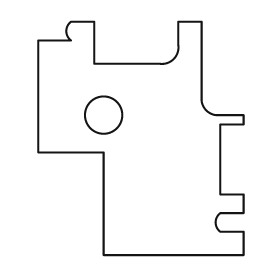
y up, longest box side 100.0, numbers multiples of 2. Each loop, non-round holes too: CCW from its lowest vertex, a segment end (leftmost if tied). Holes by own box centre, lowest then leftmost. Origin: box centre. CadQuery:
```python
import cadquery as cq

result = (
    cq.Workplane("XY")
    .moveTo(-16.0, -50.0)
    .lineTo(44.0, -50.0)
    .lineTo(44.0, -40.0)
    .lineTo(34.0, -40.0)
    .threePointArc((32.0, -36.0), (34.0, -32.0))
    .lineTo(44.0, -32.0)
    .lineTo(44.0, -24.0)
    .lineTo(34.0, -24.0)
    .lineTo(34.0, 6.0)
    .lineTo(44.0, 6.0)
    .lineTo(44.0, 10.0)
    .lineTo(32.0, 10.0)
    .threePointArc((28.0, 12.0), (26.0, 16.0))
    .lineTo(26.0, 50.0)
    .lineTo(16.0, 50.0)
    .lineTo(16.0, 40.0)
    .threePointArc((14.0, 34.0), (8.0, 32.0))
    .lineTo(-20.0, 32.0)
    .lineTo(-20.0, 50.0)
    .lineTo(-30.0, 50.0)
    .threePointArc((-32.0, 46.0), (-30.0, 42.0))
    .lineTo(-44.0, 42.0)
    .lineTo(-44.0, -6.0)
    .lineTo(-16.0, -6.0)
    .close()
    .moveTo(-16.0, 10.0)
    .circle(8.0)
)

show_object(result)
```